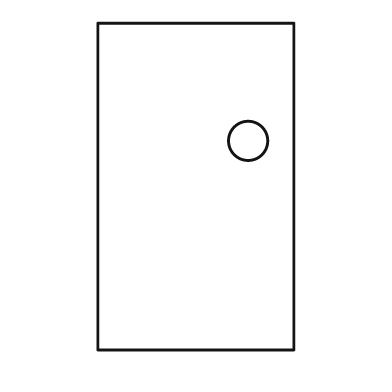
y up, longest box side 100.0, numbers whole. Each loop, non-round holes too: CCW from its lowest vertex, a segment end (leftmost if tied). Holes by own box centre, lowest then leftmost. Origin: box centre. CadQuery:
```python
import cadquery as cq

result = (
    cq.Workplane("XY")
    .moveTo(-30.0, -50.0)
    .lineTo(30.0, -50.0)
    .lineTo(30.0, 50.0)
    .lineTo(-30.0, 50.0)
    .close()
    .moveTo(16.0, 14.0)
    .circle(6.0)
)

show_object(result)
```